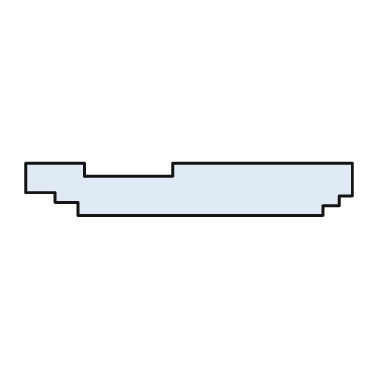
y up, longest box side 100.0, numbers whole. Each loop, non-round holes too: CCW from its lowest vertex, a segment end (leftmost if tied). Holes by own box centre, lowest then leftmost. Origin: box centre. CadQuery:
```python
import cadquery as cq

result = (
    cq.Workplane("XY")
    .moveTo(-34.0, -8.0)
    .lineTo(41.0, -8.0)
    .lineTo(41.0, -5.0)
    .lineTo(46.0, -5.0)
    .lineTo(46.0, -2.0)
    .lineTo(50.0, -2.0)
    .lineTo(50.0, 8.0)
    .lineTo(-5.0, 8.0)
    .lineTo(-5.0, 4.0)
    .lineTo(-32.0, 4.0)
    .lineTo(-32.0, 8.0)
    .lineTo(-50.0, 8.0)
    .lineTo(-50.0, -1.0)
    .lineTo(-41.0, -1.0)
    .lineTo(-41.0, -4.0)
    .lineTo(-34.0, -4.0)
    .close()
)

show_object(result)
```